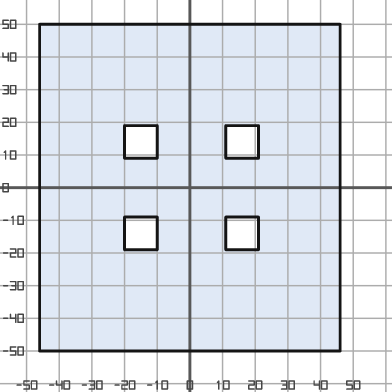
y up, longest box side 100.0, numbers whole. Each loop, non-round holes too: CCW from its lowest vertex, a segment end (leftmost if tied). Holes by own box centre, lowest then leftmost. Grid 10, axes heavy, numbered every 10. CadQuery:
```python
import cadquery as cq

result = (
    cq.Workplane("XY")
    .moveTo(-46.0, -50.0)
    .lineTo(46.0, -50.0)
    .lineTo(46.0, 50.0)
    .lineTo(-46.0, 50.0)
    .close()
    .moveTo(-20.0, -19.0)
    .lineTo(-10.0, -19.0)
    .lineTo(-10.0, -9.0)
    .lineTo(-20.0, -9.0)
    .close()
    .moveTo(11.0, -19.0)
    .lineTo(21.0, -19.0)
    .lineTo(21.0, -9.0)
    .lineTo(11.0, -9.0)
    .close()
    .moveTo(-20.0, 9.0)
    .lineTo(-10.0, 9.0)
    .lineTo(-10.0, 19.0)
    .lineTo(-20.0, 19.0)
    .close()
    .moveTo(11.0, 9.0)
    .lineTo(21.0, 9.0)
    .lineTo(21.0, 19.0)
    .lineTo(11.0, 19.0)
    .close()
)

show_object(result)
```